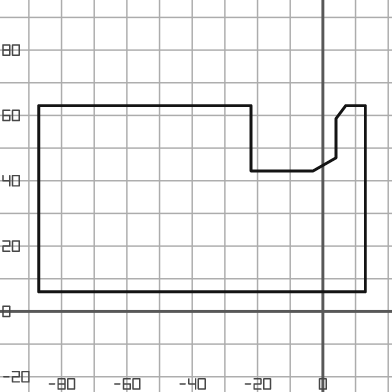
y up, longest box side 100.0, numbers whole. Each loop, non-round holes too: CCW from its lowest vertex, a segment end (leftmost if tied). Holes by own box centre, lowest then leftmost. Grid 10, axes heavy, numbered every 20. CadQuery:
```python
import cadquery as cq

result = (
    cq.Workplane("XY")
    .moveTo(-87.0, 6.0)
    .lineTo(13.0, 6.0)
    .lineTo(13.0, 63.0)
    .lineTo(7.0, 63.0)
    .lineTo(4.0, 59.0)
    .lineTo(4.0, 47.0)
    .lineTo(-3.0, 43.0)
    .lineTo(-22.0, 43.0)
    .lineTo(-22.0, 63.0)
    .lineTo(-87.0, 63.0)
    .close()
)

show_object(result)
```